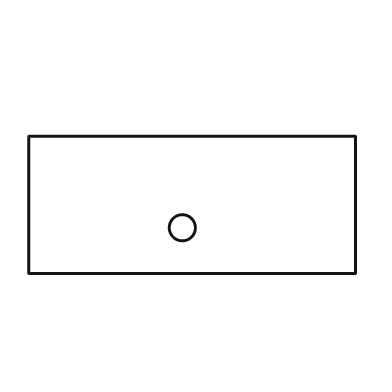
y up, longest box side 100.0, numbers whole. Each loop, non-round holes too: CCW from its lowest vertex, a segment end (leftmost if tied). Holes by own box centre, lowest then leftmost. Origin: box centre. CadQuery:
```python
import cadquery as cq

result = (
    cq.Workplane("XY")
    .moveTo(-50.0, -21.0)
    .lineTo(50.0, -21.0)
    .lineTo(50.0, 21.0)
    .lineTo(-50.0, 21.0)
    .close()
    .moveTo(-3.0, -7.0)
    .circle(4.0)
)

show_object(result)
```